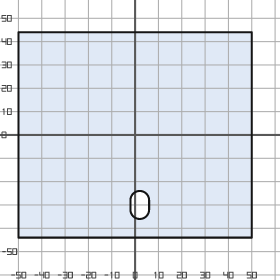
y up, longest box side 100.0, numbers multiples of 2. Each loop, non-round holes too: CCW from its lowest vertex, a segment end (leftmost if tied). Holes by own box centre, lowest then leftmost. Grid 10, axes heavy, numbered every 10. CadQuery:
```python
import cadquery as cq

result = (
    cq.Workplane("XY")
    .moveTo(-50.0, -44.0)
    .lineTo(50.0, -44.0)
    .lineTo(50.0, 44.0)
    .lineTo(-50.0, 44.0)
    .close()
    .moveTo(-2.0, -32.0)
    .threePointArc((2.0, -36.0), (6.0, -32.0))
    .lineTo(6.0, -28.0)
    .threePointArc((2.0, -24.0), (-2.0, -28.0))
    .close()
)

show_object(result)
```